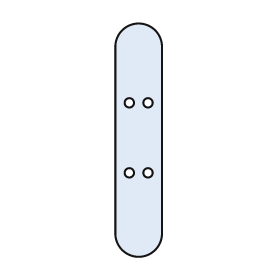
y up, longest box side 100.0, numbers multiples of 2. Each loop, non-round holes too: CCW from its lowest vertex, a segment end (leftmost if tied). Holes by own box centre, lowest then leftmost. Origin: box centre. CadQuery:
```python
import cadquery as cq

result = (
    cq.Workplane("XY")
    .moveTo(-10.0, -40.0)
    .threePointArc((0.0, -50.0), (10.0, -40.0))
    .lineTo(10.0, 40.0)
    .threePointArc((0.0, 50.0), (-10.0, 40.0))
    .close()
    .moveTo(-4.0, -14.0)
    .circle(2.0)
    .moveTo(4.0, -14.0)
    .circle(2.0)
    .moveTo(-4.0, 16.0)
    .circle(2.0)
    .moveTo(4.0, 16.0)
    .circle(2.0)
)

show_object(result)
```